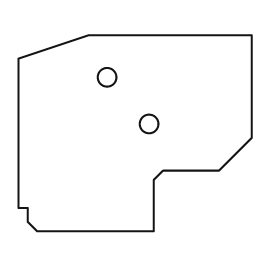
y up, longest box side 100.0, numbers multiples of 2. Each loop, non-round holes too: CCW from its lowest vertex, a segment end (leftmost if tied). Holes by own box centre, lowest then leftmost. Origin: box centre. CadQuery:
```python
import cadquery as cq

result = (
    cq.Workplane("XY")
    .moveTo(-42.0, -42.0)
    .lineTo(8.0, -42.0)
    .lineTo(8.0, -20.0)
    .lineTo(12.0, -16.0)
    .lineTo(36.0, -16.0)
    .lineTo(50.0, -2.0)
    .lineTo(50.0, 42.0)
    .lineTo(-20.0, 42.0)
    .lineTo(-50.0, 32.0)
    .lineTo(-50.0, -32.0)
    .lineTo(-46.0, -32.0)
    .lineTo(-46.0, -38.0)
    .close()
    .moveTo(6.0, 4.0)
    .circle(4.0)
    .moveTo(-12.0, 24.0)
    .circle(4.0)
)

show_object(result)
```